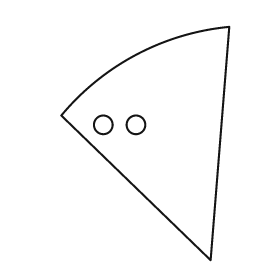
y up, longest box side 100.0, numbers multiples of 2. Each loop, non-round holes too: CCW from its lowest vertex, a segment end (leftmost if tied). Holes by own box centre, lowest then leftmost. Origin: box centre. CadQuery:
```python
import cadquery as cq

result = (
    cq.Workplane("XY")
    .moveTo(28.0, -50.0)
    .lineTo(36.0, 50.0)
    .threePointArc((-4.0, 38.0), (-36.0, 12.0))
    .close()
    .moveTo(-18.0, 8.0)
    .circle(4.0)
    .moveTo(-4.0, 8.0)
    .circle(4.0)
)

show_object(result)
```